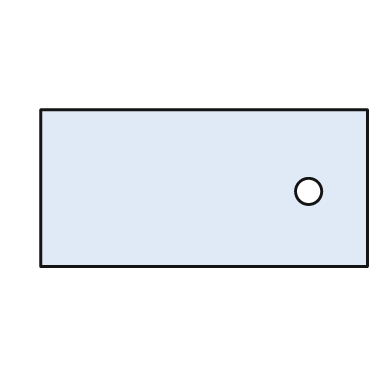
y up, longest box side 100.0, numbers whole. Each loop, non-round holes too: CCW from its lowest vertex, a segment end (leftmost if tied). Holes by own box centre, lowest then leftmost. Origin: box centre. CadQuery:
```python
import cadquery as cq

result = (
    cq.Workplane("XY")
    .moveTo(-50.0, -24.0)
    .lineTo(50.0, -24.0)
    .lineTo(50.0, 24.0)
    .lineTo(-50.0, 24.0)
    .close()
    .moveTo(32.0, -1.0)
    .circle(4.0)
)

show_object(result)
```